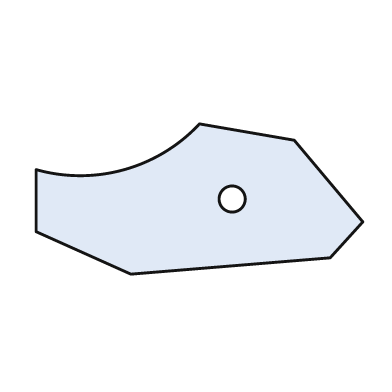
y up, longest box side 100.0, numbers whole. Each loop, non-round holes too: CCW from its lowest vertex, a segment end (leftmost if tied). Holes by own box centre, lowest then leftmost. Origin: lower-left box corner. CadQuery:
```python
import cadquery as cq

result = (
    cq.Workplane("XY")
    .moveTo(29.0, 0.0)
    .lineTo(90.0, 5.0)
    .lineTo(100.0, 16.0)
    .lineTo(79.0, 41.0)
    .lineTo(50.0, 46.0)
    .threePointArc((27.0, 32.0), (0.0, 32.0))
    .lineTo(0.0, 13.0)
    .close()
    .moveTo(60.0, 23.0)
    .circle(4.0)
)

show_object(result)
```